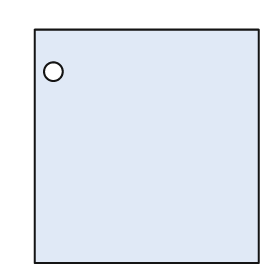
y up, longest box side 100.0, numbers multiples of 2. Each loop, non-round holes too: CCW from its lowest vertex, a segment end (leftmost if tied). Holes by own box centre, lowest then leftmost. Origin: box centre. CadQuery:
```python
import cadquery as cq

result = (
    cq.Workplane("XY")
    .moveTo(-48.0, -50.0)
    .lineTo(48.0, -50.0)
    .lineTo(48.0, 50.0)
    .lineTo(-48.0, 50.0)
    .close()
    .moveTo(-40.0, 32.0)
    .circle(4.0)
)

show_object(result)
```